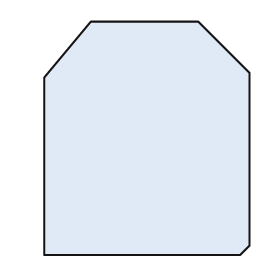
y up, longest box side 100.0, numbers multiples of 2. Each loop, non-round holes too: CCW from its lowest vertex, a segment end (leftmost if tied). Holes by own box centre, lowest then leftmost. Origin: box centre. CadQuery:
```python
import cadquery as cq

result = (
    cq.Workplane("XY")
    .moveTo(-44.0, -50.0)
    .lineTo(40.0, -50.0)
    .lineTo(44.0, -46.0)
    .lineTo(44.0, 28.0)
    .lineTo(22.0, 50.0)
    .lineTo(-24.0, 50.0)
    .lineTo(-44.0, 26.0)
    .close()
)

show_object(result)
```